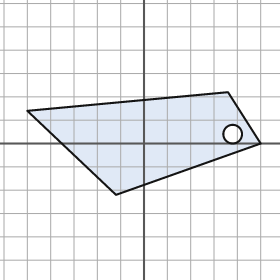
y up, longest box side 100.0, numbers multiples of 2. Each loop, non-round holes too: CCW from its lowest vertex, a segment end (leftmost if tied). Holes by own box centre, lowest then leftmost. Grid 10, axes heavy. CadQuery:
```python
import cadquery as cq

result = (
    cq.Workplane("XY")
    .moveTo(-12.0, -22.0)
    .lineTo(50.0, 0.0)
    .lineTo(36.0, 22.0)
    .lineTo(-50.0, 14.0)
    .close()
    .moveTo(38.0, 4.0)
    .circle(4.0)
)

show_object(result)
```